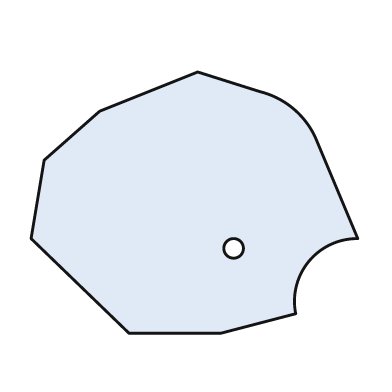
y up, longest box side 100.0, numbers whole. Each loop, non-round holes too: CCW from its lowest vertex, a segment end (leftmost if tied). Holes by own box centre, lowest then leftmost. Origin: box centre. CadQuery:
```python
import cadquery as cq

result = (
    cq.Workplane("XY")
    .moveTo(-20.0, -40.0)
    .lineTo(8.0, -40.0)
    .lineTo(31.0, -34.0)
    .threePointArc((35.0, -18.0), (50.0, -11.0))
    .lineTo(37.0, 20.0)
    .threePointArc((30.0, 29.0), (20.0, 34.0))
    .lineTo(1.0, 40.0)
    .lineTo(-29.0, 28.0)
    .lineTo(-46.0, 13.0)
    .lineTo(-50.0, -11.0)
    .close()
    .moveTo(12.0, -14.0)
    .circle(3.0)
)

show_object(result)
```